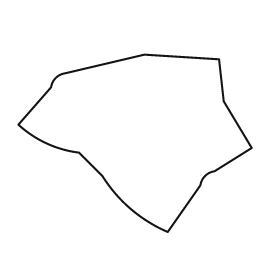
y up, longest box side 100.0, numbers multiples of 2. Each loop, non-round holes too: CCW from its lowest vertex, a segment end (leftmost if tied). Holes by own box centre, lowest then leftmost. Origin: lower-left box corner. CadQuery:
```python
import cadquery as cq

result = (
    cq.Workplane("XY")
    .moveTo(64.0, 0.0)
    .lineTo(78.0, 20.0)
    .threePointArc((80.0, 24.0), (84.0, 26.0))
    .lineTo(100.0, 36.0)
    .lineTo(88.0, 56.0)
    .lineTo(86.0, 74.0)
    .lineTo(54.0, 76.0)
    .lineTo(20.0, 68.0)
    .threePointArc((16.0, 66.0), (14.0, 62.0))
    .lineTo(0.0, 46.0)
    .threePointArc((12.0, 38.0), (26.0, 34.0))
    .lineTo(36.0, 24.0)
    .threePointArc((48.0, 10.0), (64.0, 0.0))
    .close()
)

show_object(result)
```